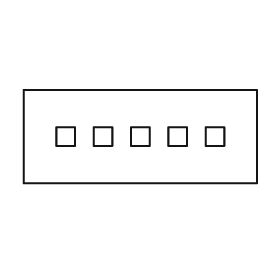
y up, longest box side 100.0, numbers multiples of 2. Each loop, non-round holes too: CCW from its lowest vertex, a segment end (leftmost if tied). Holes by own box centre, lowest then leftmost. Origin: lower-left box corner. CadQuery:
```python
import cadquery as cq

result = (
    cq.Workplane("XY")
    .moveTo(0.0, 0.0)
    .lineTo(100.0, 0.0)
    .lineTo(100.0, 40.0)
    .lineTo(0.0, 40.0)
    .close()
    .moveTo(14.0, 16.0)
    .lineTo(22.0, 16.0)
    .lineTo(22.0, 24.0)
    .lineTo(14.0, 24.0)
    .close()
    .moveTo(30.0, 16.0)
    .lineTo(38.0, 16.0)
    .lineTo(38.0, 24.0)
    .lineTo(30.0, 24.0)
    .close()
    .moveTo(46.0, 16.0)
    .lineTo(54.0, 16.0)
    .lineTo(54.0, 24.0)
    .lineTo(46.0, 24.0)
    .close()
    .moveTo(62.0, 16.0)
    .lineTo(70.0, 16.0)
    .lineTo(70.0, 24.0)
    .lineTo(62.0, 24.0)
    .close()
    .moveTo(78.0, 16.0)
    .lineTo(86.0, 16.0)
    .lineTo(86.0, 24.0)
    .lineTo(78.0, 24.0)
    .close()
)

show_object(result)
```